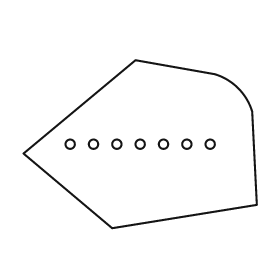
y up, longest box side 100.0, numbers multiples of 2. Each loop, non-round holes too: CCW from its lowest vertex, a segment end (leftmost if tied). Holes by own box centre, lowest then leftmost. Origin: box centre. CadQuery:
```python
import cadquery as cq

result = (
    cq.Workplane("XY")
    .moveTo(-12.0, -36.0)
    .lineTo(50.0, -26.0)
    .lineTo(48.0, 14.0)
    .threePointArc((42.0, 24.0), (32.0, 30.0))
    .lineTo(-2.0, 36.0)
    .lineTo(-50.0, -4.0)
    .close()
    .moveTo(-30.0, 0.0)
    .circle(2.0)
    .moveTo(-20.0, 0.0)
    .circle(2.0)
    .moveTo(-10.0, 0.0)
    .circle(2.0)
    .moveTo(0.0, 0.0)
    .circle(2.0)
    .moveTo(10.0, 0.0)
    .circle(2.0)
    .moveTo(20.0, 0.0)
    .circle(2.0)
    .moveTo(30.0, 0.0)
    .circle(2.0)
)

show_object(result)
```